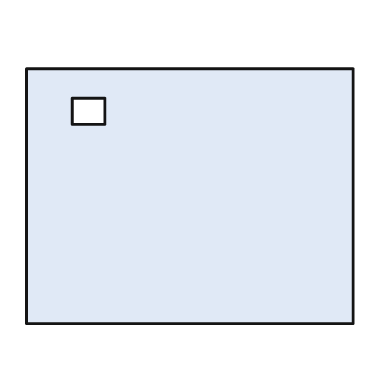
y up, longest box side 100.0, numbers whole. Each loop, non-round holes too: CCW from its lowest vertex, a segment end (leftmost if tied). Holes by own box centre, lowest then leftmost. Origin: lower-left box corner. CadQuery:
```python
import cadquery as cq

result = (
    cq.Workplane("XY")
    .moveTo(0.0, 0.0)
    .lineTo(100.0, 0.0)
    .lineTo(100.0, 78.0)
    .lineTo(0.0, 78.0)
    .close()
    .moveTo(14.0, 61.0)
    .lineTo(24.0, 61.0)
    .lineTo(24.0, 69.0)
    .lineTo(14.0, 69.0)
    .close()
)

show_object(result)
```